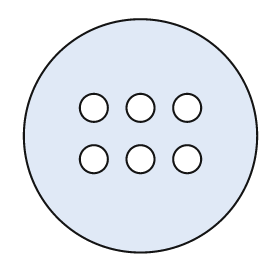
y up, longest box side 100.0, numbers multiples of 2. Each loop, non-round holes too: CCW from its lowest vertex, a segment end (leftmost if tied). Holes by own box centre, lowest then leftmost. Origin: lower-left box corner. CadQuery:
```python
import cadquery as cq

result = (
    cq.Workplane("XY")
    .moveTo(50.0, 50.0)
    .circle(50.0)
    .moveTo(30.0, 40.0)
    .circle(6.0)
    .moveTo(50.0, 40.0)
    .circle(6.0)
    .moveTo(70.0, 40.0)
    .circle(6.0)
    .moveTo(30.0, 62.0)
    .circle(6.0)
    .moveTo(50.0, 62.0)
    .circle(6.0)
    .moveTo(70.0, 62.0)
    .circle(6.0)
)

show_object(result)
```